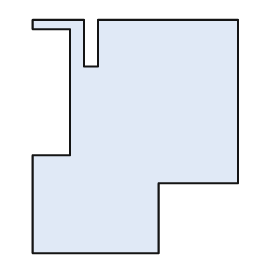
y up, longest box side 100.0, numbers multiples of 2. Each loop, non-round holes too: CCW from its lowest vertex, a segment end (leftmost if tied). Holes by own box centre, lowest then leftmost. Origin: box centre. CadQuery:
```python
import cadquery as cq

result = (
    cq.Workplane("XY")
    .moveTo(-44.0, -50.0)
    .lineTo(10.0, -50.0)
    .lineTo(10.0, -20.0)
    .lineTo(44.0, -20.0)
    .lineTo(44.0, 50.0)
    .lineTo(-16.0, 50.0)
    .lineTo(-16.0, 30.0)
    .lineTo(-22.0, 30.0)
    .lineTo(-22.0, 50.0)
    .lineTo(-44.0, 50.0)
    .lineTo(-44.0, 46.0)
    .lineTo(-28.0, 46.0)
    .lineTo(-28.0, -8.0)
    .lineTo(-44.0, -8.0)
    .close()
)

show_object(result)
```